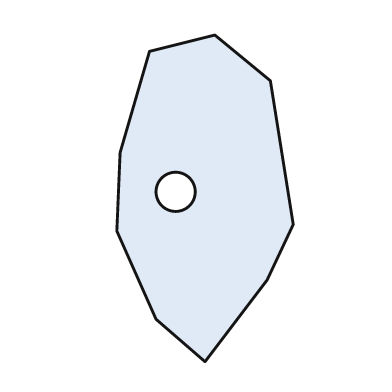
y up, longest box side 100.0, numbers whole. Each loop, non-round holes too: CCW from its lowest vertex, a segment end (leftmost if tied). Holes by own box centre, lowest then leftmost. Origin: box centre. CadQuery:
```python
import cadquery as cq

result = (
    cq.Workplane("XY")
    .moveTo(0.0, -50.0)
    .lineTo(19.0, -25.0)
    .lineTo(27.0, -8.0)
    .lineTo(20.0, 36.0)
    .lineTo(3.0, 50.0)
    .lineTo(-17.0, 45.0)
    .lineTo(-26.0, 14.0)
    .lineTo(-27.0, -10.0)
    .lineTo(-15.0, -37.0)
    .close()
    .moveTo(-9.0, 2.0)
    .circle(6.0)
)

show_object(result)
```